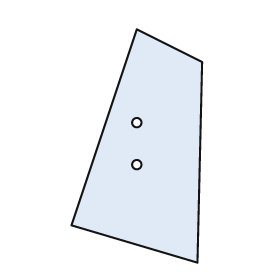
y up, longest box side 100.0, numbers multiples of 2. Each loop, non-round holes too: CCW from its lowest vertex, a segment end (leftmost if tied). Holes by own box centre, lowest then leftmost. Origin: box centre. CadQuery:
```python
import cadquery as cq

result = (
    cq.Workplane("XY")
    .moveTo(26.0, -50.0)
    .lineTo(28.0, 36.0)
    .lineTo(0.0, 50.0)
    .lineTo(-28.0, -34.0)
    .close()
    .moveTo(0.0, -8.0)
    .circle(2.0)
    .moveTo(0.0, 10.0)
    .circle(2.0)
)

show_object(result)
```